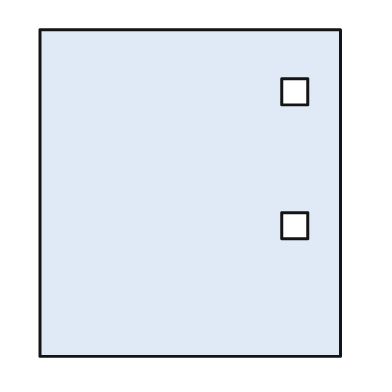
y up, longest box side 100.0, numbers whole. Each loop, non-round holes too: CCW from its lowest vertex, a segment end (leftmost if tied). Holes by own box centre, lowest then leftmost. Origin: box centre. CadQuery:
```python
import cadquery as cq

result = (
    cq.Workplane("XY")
    .moveTo(-46.0, -50.0)
    .lineTo(46.0, -50.0)
    .lineTo(46.0, 50.0)
    .lineTo(-46.0, 50.0)
    .close()
    .moveTo(28.0, -14.0)
    .lineTo(36.0, -14.0)
    .lineTo(36.0, -6.0)
    .lineTo(28.0, -6.0)
    .close()
    .moveTo(28.0, 27.0)
    .lineTo(36.0, 27.0)
    .lineTo(36.0, 35.0)
    .lineTo(28.0, 35.0)
    .close()
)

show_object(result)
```